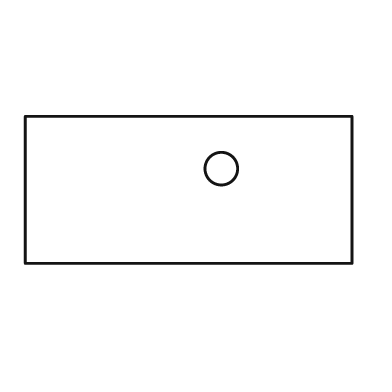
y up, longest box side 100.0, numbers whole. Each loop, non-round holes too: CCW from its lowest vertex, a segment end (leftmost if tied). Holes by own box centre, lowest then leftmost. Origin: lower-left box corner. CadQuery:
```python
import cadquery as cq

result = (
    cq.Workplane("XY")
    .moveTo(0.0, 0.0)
    .lineTo(100.0, 0.0)
    .lineTo(100.0, 45.0)
    .lineTo(0.0, 45.0)
    .close()
    .moveTo(60.0, 29.0)
    .circle(5.0)
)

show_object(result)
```